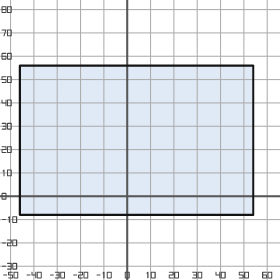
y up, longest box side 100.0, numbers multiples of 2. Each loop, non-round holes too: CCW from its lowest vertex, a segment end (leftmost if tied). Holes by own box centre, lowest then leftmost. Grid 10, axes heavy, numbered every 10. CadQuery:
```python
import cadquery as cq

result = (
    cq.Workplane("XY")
    .moveTo(-46.0, -8.0)
    .lineTo(54.0, -8.0)
    .lineTo(54.0, 56.0)
    .lineTo(-46.0, 56.0)
    .close()
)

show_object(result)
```